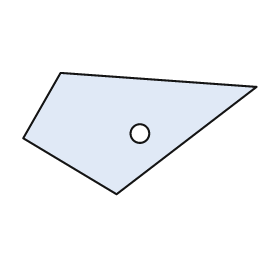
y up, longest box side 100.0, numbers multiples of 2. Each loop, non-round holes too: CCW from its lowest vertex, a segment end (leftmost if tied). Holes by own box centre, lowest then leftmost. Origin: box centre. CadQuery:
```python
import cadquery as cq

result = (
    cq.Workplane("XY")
    .moveTo(-10.0, -26.0)
    .lineTo(50.0, 20.0)
    .lineTo(-34.0, 26.0)
    .lineTo(-50.0, -2.0)
    .close()
    .moveTo(0.0, 0.0)
    .circle(4.0)
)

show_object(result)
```